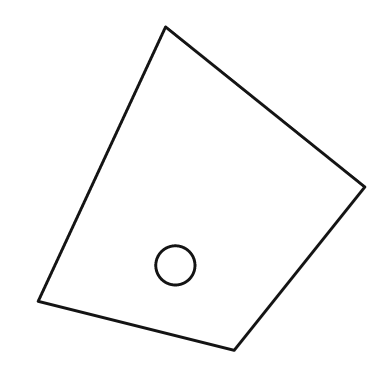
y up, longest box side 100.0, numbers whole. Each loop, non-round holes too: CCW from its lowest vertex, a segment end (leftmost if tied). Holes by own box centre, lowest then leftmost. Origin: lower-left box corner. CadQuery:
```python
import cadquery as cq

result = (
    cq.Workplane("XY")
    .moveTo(60.0, 0.0)
    .lineTo(100.0, 50.0)
    .lineTo(39.0, 99.0)
    .lineTo(0.0, 15.0)
    .close()
    .moveTo(42.0, 26.0)
    .circle(6.0)
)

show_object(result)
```